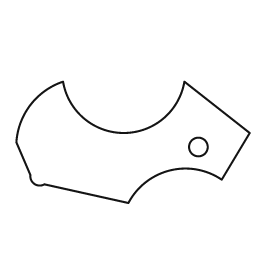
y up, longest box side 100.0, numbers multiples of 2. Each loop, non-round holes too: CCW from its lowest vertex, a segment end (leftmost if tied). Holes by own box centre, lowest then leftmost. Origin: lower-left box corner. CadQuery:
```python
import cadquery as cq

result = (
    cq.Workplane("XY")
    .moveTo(48.0, 0.0)
    .threePointArc((66.0, 14.0), (88.0, 10.0))
    .lineTo(100.0, 30.0)
    .lineTo(72.0, 52.0)
    .threePointArc((46.0, 30.0), (20.0, 52.0))
    .threePointArc((6.0, 42.0), (0.0, 26.0))
    .lineTo(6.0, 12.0)
    .threePointArc((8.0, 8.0), (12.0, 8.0))
    .close()
    .moveTo(78.0, 24.0)
    .circle(4.0)
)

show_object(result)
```